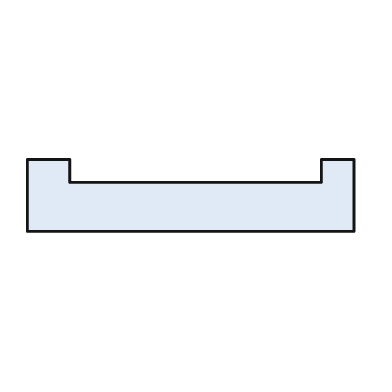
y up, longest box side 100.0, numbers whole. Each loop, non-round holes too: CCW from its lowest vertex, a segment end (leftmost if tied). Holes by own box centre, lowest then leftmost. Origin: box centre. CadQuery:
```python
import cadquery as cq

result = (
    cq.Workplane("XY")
    .moveTo(-50.0, -11.0)
    .lineTo(50.0, -11.0)
    .lineTo(50.0, 11.0)
    .lineTo(40.0, 11.0)
    .lineTo(40.0, 4.0)
    .lineTo(-37.0, 4.0)
    .lineTo(-37.0, 11.0)
    .lineTo(-50.0, 11.0)
    .close()
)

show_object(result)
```